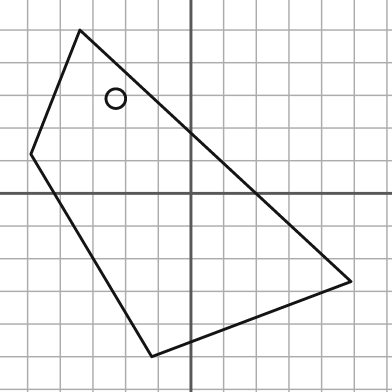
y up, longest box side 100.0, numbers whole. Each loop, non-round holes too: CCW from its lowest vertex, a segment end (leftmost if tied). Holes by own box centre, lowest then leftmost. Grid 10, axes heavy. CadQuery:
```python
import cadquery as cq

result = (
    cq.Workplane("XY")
    .moveTo(-12.0, -50.0)
    .lineTo(49.0, -27.0)
    .lineTo(-34.0, 50.0)
    .lineTo(-49.0, 12.0)
    .close()
    .moveTo(-23.0, 29.0)
    .circle(3.0)
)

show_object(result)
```